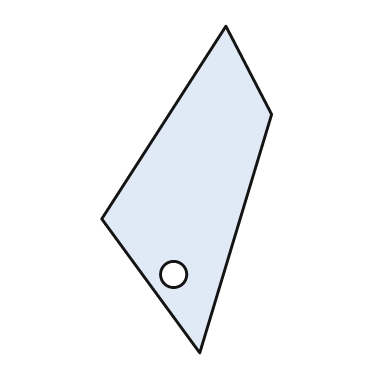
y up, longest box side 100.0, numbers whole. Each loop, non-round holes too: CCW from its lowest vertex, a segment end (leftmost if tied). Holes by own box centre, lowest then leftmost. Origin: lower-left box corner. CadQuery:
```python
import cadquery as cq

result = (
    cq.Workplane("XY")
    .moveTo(30.0, 0.0)
    .lineTo(52.0, 73.0)
    .lineTo(38.0, 100.0)
    .lineTo(0.0, 41.0)
    .close()
    .moveTo(22.0, 24.0)
    .circle(4.0)
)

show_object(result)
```